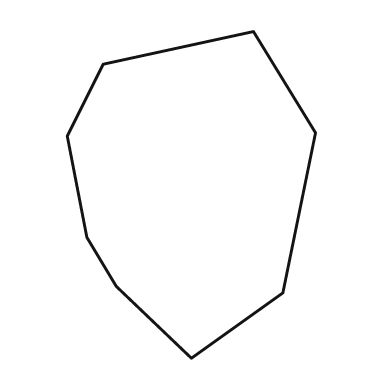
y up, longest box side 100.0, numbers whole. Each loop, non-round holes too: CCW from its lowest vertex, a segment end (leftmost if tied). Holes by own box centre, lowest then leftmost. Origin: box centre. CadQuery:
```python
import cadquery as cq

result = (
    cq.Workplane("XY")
    .moveTo(0.0, -50.0)
    .lineTo(28.0, -30.0)
    .lineTo(38.0, 19.0)
    .lineTo(19.0, 50.0)
    .lineTo(-27.0, 40.0)
    .lineTo(-38.0, 18.0)
    .lineTo(-32.0, -13.0)
    .lineTo(-23.0, -28.0)
    .close()
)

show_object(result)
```